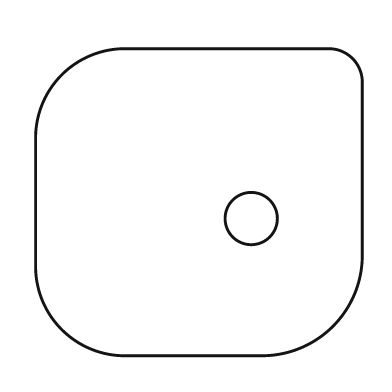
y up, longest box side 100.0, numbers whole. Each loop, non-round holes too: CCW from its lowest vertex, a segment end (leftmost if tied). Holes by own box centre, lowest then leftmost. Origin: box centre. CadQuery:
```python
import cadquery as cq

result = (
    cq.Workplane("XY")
    .moveTo(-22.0, -47.0)
    .lineTo(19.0, -47.0)
    .threePointArc((41.0, -38.0), (50.0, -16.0))
    .lineTo(50.0, 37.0)
    .threePointArc((47.0, 44.0), (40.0, 47.0))
    .lineTo(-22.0, 47.0)
    .threePointArc((-42.0, 39.0), (-50.0, 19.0))
    .lineTo(-50.0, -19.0)
    .threePointArc((-42.0, -39.0), (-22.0, -47.0))
    .close()
    .moveTo(16.0, -5.0)
    .circle(8.0)
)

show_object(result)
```